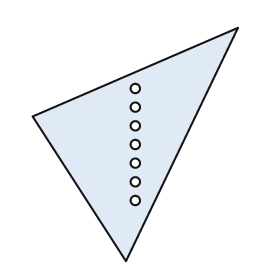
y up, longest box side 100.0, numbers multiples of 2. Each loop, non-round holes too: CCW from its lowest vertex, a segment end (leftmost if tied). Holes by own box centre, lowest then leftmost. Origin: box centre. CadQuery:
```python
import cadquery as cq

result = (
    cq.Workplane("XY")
    .moveTo(-4.0, -50.0)
    .lineTo(44.0, 50.0)
    .lineTo(-44.0, 12.0)
    .close()
    .moveTo(0.0, -24.0)
    .circle(2.0)
    .moveTo(0.0, -16.0)
    .circle(2.0)
    .moveTo(0.0, -8.0)
    .circle(2.0)
    .moveTo(0.0, 0.0)
    .circle(2.0)
    .moveTo(0.0, 8.0)
    .circle(2.0)
    .moveTo(0.0, 16.0)
    .circle(2.0)
    .moveTo(0.0, 24.0)
    .circle(2.0)
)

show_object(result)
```